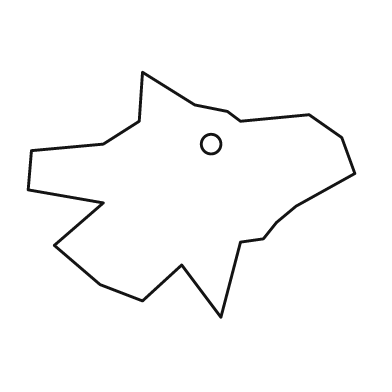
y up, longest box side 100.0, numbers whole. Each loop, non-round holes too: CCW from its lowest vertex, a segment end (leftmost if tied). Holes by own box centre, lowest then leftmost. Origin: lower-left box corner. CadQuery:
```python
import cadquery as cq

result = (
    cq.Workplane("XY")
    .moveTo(59.0, 0.0)
    .lineTo(65.0, 23.0)
    .lineTo(72.0, 24.0)
    .lineTo(76.0, 29.0)
    .lineTo(82.0, 34.0)
    .lineTo(100.0, 44.0)
    .lineTo(96.0, 55.0)
    .lineTo(86.0, 62.0)
    .lineTo(65.0, 60.0)
    .lineTo(61.0, 63.0)
    .lineTo(51.0, 65.0)
    .lineTo(35.0, 75.0)
    .lineTo(34.0, 60.0)
    .lineTo(23.0, 53.0)
    .lineTo(1.0, 51.0)
    .lineTo(0.0, 39.0)
    .lineTo(23.0, 35.0)
    .lineTo(8.0, 22.0)
    .lineTo(22.0, 10.0)
    .lineTo(35.0, 5.0)
    .lineTo(47.0, 16.0)
    .close()
    .moveTo(56.0, 53.0)
    .circle(3.0)
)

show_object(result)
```